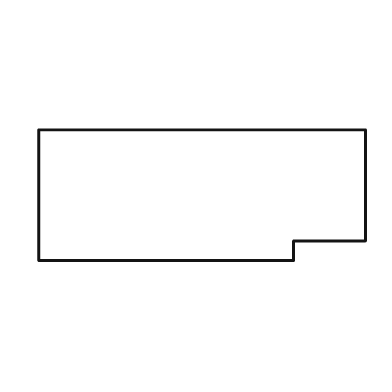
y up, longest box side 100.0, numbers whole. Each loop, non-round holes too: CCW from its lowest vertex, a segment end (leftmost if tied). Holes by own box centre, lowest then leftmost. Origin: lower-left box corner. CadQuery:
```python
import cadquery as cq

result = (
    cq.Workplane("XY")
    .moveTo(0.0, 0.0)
    .lineTo(78.0, 0.0)
    .lineTo(78.0, 6.0)
    .lineTo(100.0, 6.0)
    .lineTo(100.0, 40.0)
    .lineTo(0.0, 40.0)
    .close()
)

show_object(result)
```